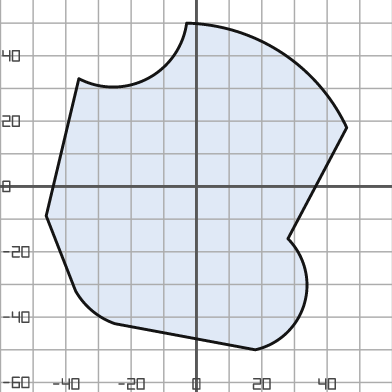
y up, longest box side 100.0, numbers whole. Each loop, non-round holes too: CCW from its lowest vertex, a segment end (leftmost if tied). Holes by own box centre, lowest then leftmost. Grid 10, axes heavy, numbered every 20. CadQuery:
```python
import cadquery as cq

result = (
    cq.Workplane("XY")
    .moveTo(18.0, -50.0)
    .threePointArc((33.0, -36.0), (28.0, -16.0))
    .lineTo(46.0, 18.0)
    .threePointArc((26.0, 41.0), (-3.0, 50.0))
    .threePointArc((-15.0, 33.0), (-36.0, 33.0))
    .lineTo(-46.0, -9.0)
    .lineTo(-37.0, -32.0)
    .threePointArc((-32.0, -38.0), (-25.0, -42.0))
    .close()
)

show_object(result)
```